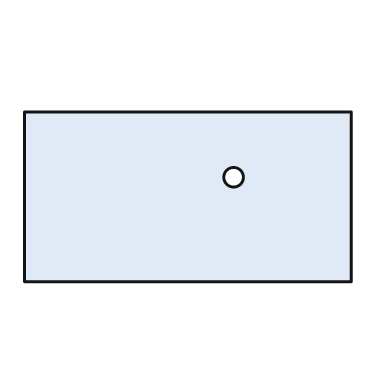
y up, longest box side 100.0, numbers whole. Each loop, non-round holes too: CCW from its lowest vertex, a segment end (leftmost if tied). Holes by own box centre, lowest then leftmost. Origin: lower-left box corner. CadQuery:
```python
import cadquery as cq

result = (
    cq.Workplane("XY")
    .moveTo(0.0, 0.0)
    .lineTo(100.0, 0.0)
    .lineTo(100.0, 52.0)
    .lineTo(0.0, 52.0)
    .close()
    .moveTo(64.0, 32.0)
    .circle(3.0)
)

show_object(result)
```